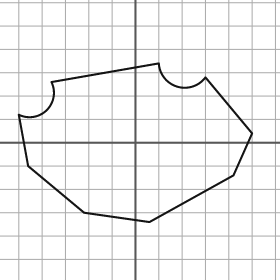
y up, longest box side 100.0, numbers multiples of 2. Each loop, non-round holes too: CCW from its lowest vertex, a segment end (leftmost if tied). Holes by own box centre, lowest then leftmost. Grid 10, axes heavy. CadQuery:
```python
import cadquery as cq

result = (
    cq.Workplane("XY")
    .moveTo(6.0, -34.0)
    .lineTo(42.0, -14.0)
    .lineTo(50.0, 4.0)
    .lineTo(30.0, 28.0)
    .threePointArc((18.0, 24.0), (10.0, 34.0))
    .lineTo(-36.0, 26.0)
    .threePointArc((-38.0, 14.0), (-50.0, 12.0))
    .lineTo(-46.0, -10.0)
    .lineTo(-22.0, -30.0)
    .close()
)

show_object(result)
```